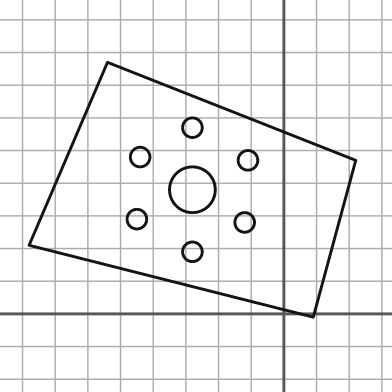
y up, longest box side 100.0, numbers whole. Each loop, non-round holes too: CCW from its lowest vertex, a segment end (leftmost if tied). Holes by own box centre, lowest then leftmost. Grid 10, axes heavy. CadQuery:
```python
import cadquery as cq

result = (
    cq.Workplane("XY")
    .moveTo(9.0, -1.0)
    .lineTo(22.0, 47.0)
    .lineTo(-54.0, 77.0)
    .lineTo(-78.0, 21.0)
    .close()
    .moveTo(-28.0, 19.0)
    .circle(3.0)
    .moveTo(-12.0, 28.0)
    .circle(3.0)
    .moveTo(-45.0, 29.0)
    .circle(3.0)
    .moveTo(-28.0, 38.0)
    .circle(7.0)
    .moveTo(-11.0, 47.0)
    .circle(3.0)
    .moveTo(-44.0, 48.0)
    .circle(3.0)
    .moveTo(-28.0, 57.0)
    .circle(3.0)
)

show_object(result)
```